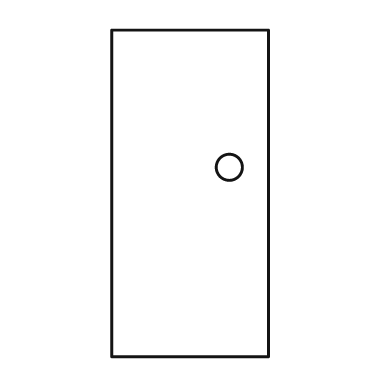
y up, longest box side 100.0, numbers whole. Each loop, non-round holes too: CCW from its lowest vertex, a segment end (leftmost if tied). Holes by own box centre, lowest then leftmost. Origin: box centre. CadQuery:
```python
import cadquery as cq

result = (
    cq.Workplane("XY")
    .moveTo(-24.0, -50.0)
    .lineTo(24.0, -50.0)
    .lineTo(24.0, 50.0)
    .lineTo(-24.0, 50.0)
    .close()
    .moveTo(12.0, 8.0)
    .circle(4.0)
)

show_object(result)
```